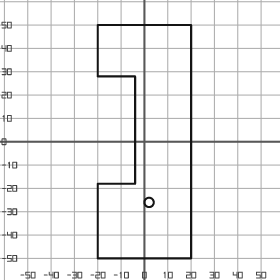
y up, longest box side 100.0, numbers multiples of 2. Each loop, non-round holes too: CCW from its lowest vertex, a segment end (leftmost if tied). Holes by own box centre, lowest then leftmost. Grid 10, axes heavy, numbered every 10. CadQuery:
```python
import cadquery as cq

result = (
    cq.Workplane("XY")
    .moveTo(-20.0, -50.0)
    .lineTo(20.0, -50.0)
    .lineTo(20.0, 50.0)
    .lineTo(-20.0, 50.0)
    .lineTo(-20.0, 28.0)
    .lineTo(-4.0, 28.0)
    .lineTo(-4.0, -18.0)
    .lineTo(-20.0, -18.0)
    .close()
    .moveTo(2.0, -26.0)
    .circle(2.0)
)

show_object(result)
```